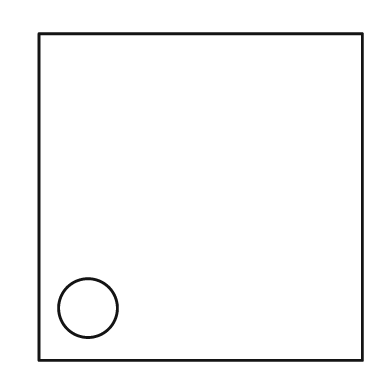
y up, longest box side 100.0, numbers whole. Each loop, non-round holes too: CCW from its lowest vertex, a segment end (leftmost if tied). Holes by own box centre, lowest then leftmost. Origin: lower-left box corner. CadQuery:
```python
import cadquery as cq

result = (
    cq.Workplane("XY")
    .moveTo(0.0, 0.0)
    .lineTo(99.0, 0.0)
    .lineTo(99.0, 100.0)
    .lineTo(0.0, 100.0)
    .close()
    .moveTo(15.0, 16.0)
    .circle(9.0)
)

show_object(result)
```